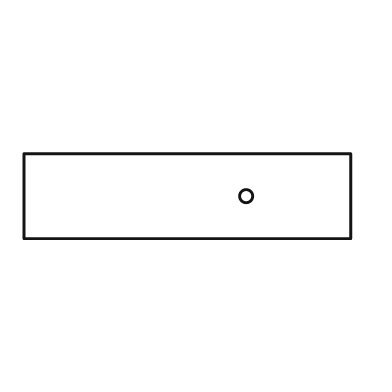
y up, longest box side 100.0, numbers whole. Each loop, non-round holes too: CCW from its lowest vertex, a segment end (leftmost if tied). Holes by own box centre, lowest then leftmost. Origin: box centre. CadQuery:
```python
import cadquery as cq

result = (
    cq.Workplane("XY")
    .moveTo(-50.0, -13.0)
    .lineTo(50.0, -13.0)
    .lineTo(50.0, 13.0)
    .lineTo(-50.0, 13.0)
    .close()
    .moveTo(18.0, 0.0)
    .circle(2.0)
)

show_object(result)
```